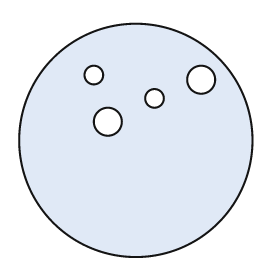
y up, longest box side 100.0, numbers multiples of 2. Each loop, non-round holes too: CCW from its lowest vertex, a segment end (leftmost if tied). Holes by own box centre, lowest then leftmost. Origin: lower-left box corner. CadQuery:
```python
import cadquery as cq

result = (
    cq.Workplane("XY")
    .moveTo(50.0, 50.0)
    .circle(50.0)
    .moveTo(38.0, 58.0)
    .circle(6.0)
    .moveTo(58.0, 68.0)
    .circle(4.0)
    .moveTo(78.0, 76.0)
    .circle(6.0)
    .moveTo(32.0, 78.0)
    .circle(4.0)
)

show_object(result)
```